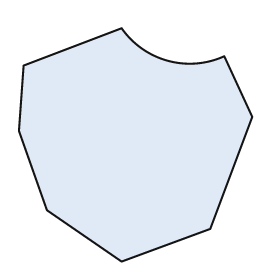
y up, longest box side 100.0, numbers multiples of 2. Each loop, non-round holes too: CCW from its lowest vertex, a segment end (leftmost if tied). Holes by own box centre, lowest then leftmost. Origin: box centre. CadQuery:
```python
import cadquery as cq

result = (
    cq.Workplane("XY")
    .moveTo(-6.0, -50.0)
    .lineTo(32.0, -36.0)
    .lineTo(50.0, 12.0)
    .lineTo(38.0, 38.0)
    .threePointArc((14.0, 36.0), (-6.0, 50.0))
    .lineTo(-48.0, 34.0)
    .lineTo(-50.0, 6.0)
    .lineTo(-38.0, -28.0)
    .close()
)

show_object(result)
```